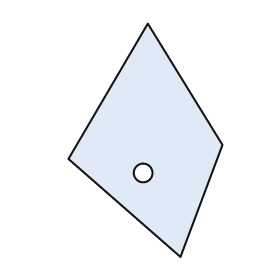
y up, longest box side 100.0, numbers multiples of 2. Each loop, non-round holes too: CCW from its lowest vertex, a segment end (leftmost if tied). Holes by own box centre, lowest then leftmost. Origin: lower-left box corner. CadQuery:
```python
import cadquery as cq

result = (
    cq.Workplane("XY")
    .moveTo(48.0, 0.0)
    .lineTo(66.0, 48.0)
    .lineTo(34.0, 100.0)
    .lineTo(0.0, 42.0)
    .close()
    .moveTo(32.0, 36.0)
    .circle(4.0)
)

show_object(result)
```